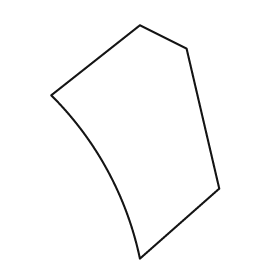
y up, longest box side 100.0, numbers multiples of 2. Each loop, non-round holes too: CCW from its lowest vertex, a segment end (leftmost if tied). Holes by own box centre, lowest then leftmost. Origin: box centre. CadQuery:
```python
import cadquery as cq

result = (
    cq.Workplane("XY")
    .moveTo(2.0, -50.0)
    .lineTo(36.0, -20.0)
    .lineTo(22.0, 40.0)
    .lineTo(2.0, 50.0)
    .lineTo(-36.0, 20.0)
    .threePointArc((-12.0, -12.0), (2.0, -50.0))
    .close()
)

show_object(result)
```